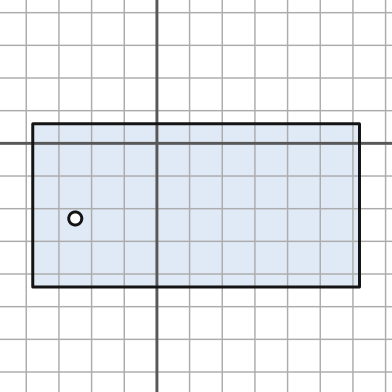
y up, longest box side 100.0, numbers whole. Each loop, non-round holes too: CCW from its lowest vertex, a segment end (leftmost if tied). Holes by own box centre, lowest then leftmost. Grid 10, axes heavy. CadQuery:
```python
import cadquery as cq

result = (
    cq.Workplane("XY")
    .moveTo(-38.0, -44.0)
    .lineTo(62.0, -44.0)
    .lineTo(62.0, 6.0)
    .lineTo(-38.0, 6.0)
    .close()
    .moveTo(-25.0, -23.0)
    .circle(2.0)
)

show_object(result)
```